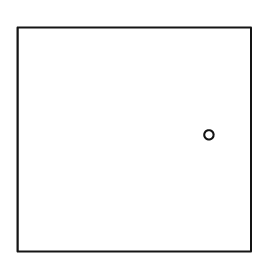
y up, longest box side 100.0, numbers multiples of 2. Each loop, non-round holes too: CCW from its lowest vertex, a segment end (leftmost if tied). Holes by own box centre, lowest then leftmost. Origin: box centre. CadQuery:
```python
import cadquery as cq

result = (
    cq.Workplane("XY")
    .moveTo(-50.0, -48.0)
    .lineTo(50.0, -48.0)
    .lineTo(50.0, 48.0)
    .lineTo(-50.0, 48.0)
    .close()
    .moveTo(32.0, 2.0)
    .circle(2.0)
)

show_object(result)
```